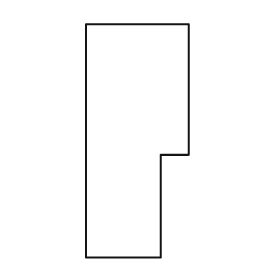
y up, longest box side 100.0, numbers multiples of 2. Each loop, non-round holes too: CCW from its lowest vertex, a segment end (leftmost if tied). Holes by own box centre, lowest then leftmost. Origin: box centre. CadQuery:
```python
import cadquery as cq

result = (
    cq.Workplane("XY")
    .moveTo(-22.0, -50.0)
    .lineTo(10.0, -50.0)
    .lineTo(10.0, -6.0)
    .lineTo(22.0, -6.0)
    .lineTo(22.0, 50.0)
    .lineTo(-22.0, 50.0)
    .close()
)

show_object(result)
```